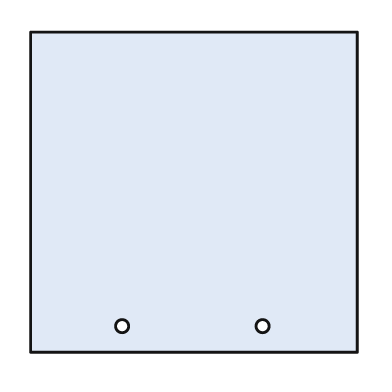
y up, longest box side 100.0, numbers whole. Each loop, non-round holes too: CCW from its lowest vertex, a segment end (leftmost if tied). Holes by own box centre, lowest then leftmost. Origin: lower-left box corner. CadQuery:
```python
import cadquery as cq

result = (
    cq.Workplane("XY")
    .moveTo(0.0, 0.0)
    .lineTo(100.0, 0.0)
    .lineTo(100.0, 98.0)
    .lineTo(0.0, 98.0)
    .close()
    .moveTo(28.0, 8.0)
    .circle(2.0)
    .moveTo(71.0, 8.0)
    .circle(2.0)
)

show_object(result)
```